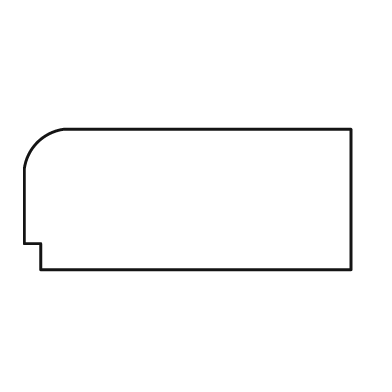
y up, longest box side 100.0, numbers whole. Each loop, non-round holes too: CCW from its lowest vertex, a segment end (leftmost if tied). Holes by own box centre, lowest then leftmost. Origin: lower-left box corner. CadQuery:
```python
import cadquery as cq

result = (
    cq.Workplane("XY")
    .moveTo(5.0, 0.0)
    .lineTo(100.0, 0.0)
    .lineTo(100.0, 43.0)
    .lineTo(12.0, 43.0)
    .threePointArc((4.0, 39.0), (0.0, 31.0))
    .lineTo(0.0, 8.0)
    .lineTo(5.0, 8.0)
    .close()
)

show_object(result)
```